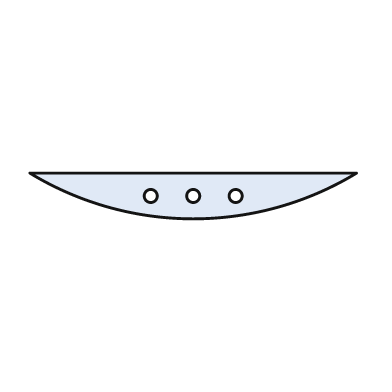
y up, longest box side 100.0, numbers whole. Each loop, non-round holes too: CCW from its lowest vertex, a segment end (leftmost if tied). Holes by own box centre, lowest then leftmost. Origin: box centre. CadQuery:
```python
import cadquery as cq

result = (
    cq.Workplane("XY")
    .moveTo(-50.0, 7.0)
    .threePointArc((0.0, -7.0), (50.0, 7.0))
    .close()
    .moveTo(-13.0, 0.0)
    .circle(2.0)
    .moveTo(0.0, 0.0)
    .circle(2.0)
    .moveTo(13.0, 0.0)
    .circle(2.0)
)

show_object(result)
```